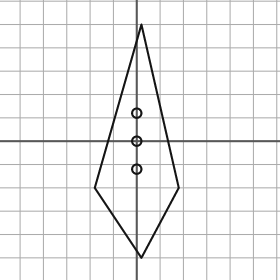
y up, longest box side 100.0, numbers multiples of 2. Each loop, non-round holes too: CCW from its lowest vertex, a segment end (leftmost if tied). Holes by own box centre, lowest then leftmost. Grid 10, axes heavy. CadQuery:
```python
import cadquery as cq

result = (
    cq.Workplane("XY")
    .moveTo(2.0, -50.0)
    .lineTo(18.0, -20.0)
    .lineTo(2.0, 50.0)
    .lineTo(-18.0, -20.0)
    .close()
    .moveTo(0.0, -12.0)
    .circle(2.0)
    .moveTo(0.0, 0.0)
    .circle(2.0)
    .moveTo(0.0, 12.0)
    .circle(2.0)
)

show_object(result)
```